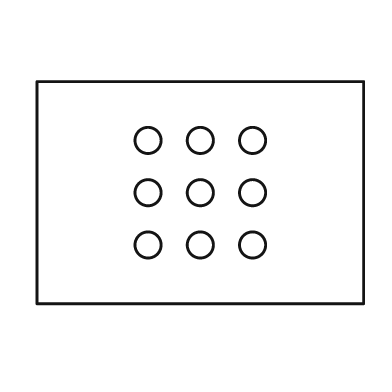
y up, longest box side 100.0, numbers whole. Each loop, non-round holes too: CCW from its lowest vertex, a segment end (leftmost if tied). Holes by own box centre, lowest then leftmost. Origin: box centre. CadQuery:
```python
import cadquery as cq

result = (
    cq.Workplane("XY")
    .moveTo(-50.0, -34.0)
    .lineTo(50.0, -34.0)
    .lineTo(50.0, 34.0)
    .lineTo(-50.0, 34.0)
    .close()
    .moveTo(-16.0, -16.0)
    .circle(4.0)
    .moveTo(0.0, -16.0)
    .circle(4.0)
    .moveTo(16.0, -16.0)
    .circle(4.0)
    .moveTo(-16.0, 0.0)
    .circle(4.0)
    .moveTo(0.0, 0.0)
    .circle(4.0)
    .moveTo(16.0, 0.0)
    .circle(4.0)
    .moveTo(-16.0, 16.0)
    .circle(4.0)
    .moveTo(0.0, 16.0)
    .circle(4.0)
    .moveTo(16.0, 16.0)
    .circle(4.0)
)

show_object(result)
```